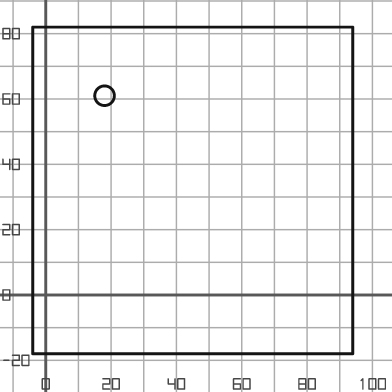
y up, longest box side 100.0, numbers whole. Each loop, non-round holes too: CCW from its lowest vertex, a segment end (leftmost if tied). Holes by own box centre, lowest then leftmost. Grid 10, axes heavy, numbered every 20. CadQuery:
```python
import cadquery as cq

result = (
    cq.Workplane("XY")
    .moveTo(-4.0, -18.0)
    .lineTo(94.0, -18.0)
    .lineTo(94.0, 82.0)
    .lineTo(-4.0, 82.0)
    .close()
    .moveTo(18.0, 61.0)
    .circle(3.0)
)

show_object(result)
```